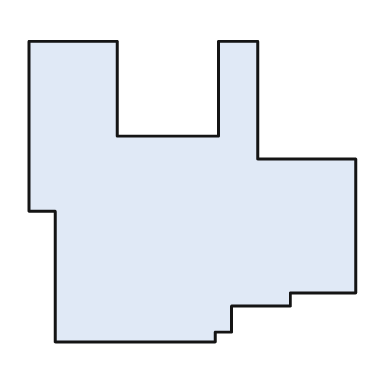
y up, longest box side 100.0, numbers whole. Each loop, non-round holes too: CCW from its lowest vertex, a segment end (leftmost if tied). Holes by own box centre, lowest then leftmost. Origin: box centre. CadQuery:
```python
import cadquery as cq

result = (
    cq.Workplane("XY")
    .moveTo(-42.0, -46.0)
    .lineTo(7.0, -46.0)
    .lineTo(7.0, -43.0)
    .lineTo(12.0, -43.0)
    .lineTo(12.0, -35.0)
    .lineTo(30.0, -35.0)
    .lineTo(30.0, -31.0)
    .lineTo(50.0, -31.0)
    .lineTo(50.0, 10.0)
    .lineTo(20.0, 10.0)
    .lineTo(20.0, 46.0)
    .lineTo(8.0, 46.0)
    .lineTo(8.0, 17.0)
    .lineTo(-23.0, 17.0)
    .lineTo(-23.0, 46.0)
    .lineTo(-50.0, 46.0)
    .lineTo(-50.0, -6.0)
    .lineTo(-42.0, -6.0)
    .close()
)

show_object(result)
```